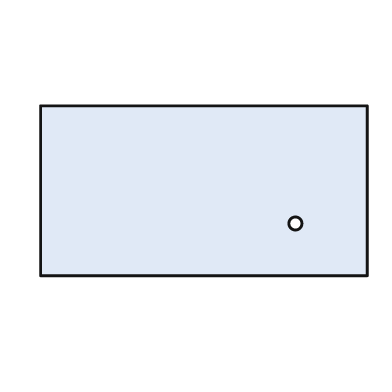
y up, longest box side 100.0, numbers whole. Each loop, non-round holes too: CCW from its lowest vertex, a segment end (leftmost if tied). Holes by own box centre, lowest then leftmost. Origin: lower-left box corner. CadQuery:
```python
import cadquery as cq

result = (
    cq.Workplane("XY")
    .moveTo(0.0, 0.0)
    .lineTo(100.0, 0.0)
    .lineTo(100.0, 52.0)
    .lineTo(0.0, 52.0)
    .close()
    .moveTo(78.0, 16.0)
    .circle(2.0)
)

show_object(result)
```